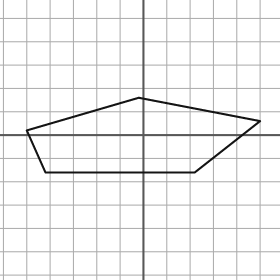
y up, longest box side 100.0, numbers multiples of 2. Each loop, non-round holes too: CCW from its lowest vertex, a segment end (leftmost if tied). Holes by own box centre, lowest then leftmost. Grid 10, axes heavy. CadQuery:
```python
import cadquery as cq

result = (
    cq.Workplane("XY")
    .moveTo(-42.0, -16.0)
    .lineTo(22.0, -16.0)
    .lineTo(50.0, 6.0)
    .lineTo(-2.0, 16.0)
    .lineTo(-50.0, 2.0)
    .close()
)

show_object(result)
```